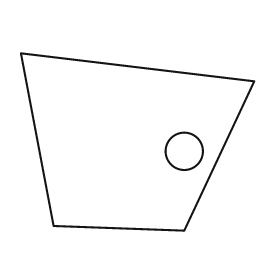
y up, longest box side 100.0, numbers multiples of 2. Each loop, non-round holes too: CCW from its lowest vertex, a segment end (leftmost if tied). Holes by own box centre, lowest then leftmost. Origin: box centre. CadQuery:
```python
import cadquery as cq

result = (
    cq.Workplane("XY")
    .moveTo(20.0, -38.0)
    .lineTo(50.0, 26.0)
    .lineTo(-50.0, 38.0)
    .lineTo(-36.0, -36.0)
    .close()
    .moveTo(20.0, -4.0)
    .circle(8.0)
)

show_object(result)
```